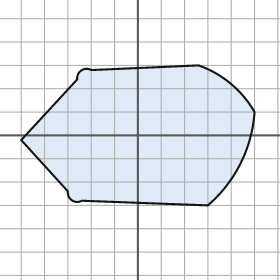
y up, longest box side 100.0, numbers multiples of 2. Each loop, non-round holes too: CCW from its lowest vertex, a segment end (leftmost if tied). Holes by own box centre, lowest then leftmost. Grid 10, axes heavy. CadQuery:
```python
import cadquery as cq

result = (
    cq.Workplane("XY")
    .moveTo(30.0, -30.0)
    .threePointArc((44.0, -12.0), (50.0, 10.0))
    .threePointArc((40.0, 22.0), (26.0, 30.0))
    .lineTo(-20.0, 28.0)
    .threePointArc((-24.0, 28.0), (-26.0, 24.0))
    .lineTo(-50.0, -2.0)
    .lineTo(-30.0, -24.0)
    .threePointArc((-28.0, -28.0), (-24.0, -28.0))
    .close()
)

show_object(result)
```